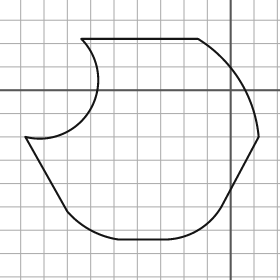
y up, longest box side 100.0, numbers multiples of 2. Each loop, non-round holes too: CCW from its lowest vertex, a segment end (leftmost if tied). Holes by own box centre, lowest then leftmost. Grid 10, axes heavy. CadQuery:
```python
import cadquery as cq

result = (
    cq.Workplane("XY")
    .moveTo(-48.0, -64.0)
    .lineTo(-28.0, -64.0)
    .threePointArc((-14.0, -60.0), (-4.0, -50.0))
    .lineTo(12.0, -20.0)
    .threePointArc((4.0, 4.0), (-14.0, 22.0))
    .lineTo(-64.0, 22.0)
    .threePointArc((-60.0, -8.0), (-88.0, -20.0))
    .lineTo(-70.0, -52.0)
    .threePointArc((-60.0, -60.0), (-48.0, -64.0))
    .close()
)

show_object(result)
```